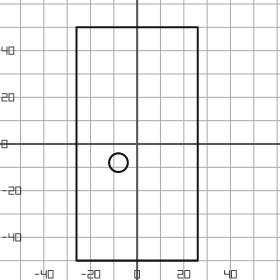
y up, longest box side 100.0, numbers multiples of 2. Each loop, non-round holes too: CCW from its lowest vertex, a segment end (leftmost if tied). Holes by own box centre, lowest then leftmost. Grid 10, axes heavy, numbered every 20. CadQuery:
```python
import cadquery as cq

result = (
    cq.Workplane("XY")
    .moveTo(-26.0, -50.0)
    .lineTo(26.0, -50.0)
    .lineTo(26.0, 50.0)
    .lineTo(-26.0, 50.0)
    .close()
    .moveTo(-8.0, -8.0)
    .circle(4.0)
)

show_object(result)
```